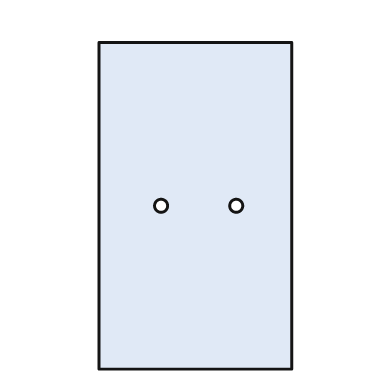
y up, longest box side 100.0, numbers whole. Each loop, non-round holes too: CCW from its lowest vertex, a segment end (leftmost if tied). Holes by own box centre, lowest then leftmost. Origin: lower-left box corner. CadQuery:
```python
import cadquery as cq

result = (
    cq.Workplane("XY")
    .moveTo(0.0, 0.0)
    .lineTo(59.0, 0.0)
    .lineTo(59.0, 100.0)
    .lineTo(0.0, 100.0)
    .close()
    .moveTo(19.0, 50.0)
    .circle(2.0)
    .moveTo(42.0, 50.0)
    .circle(2.0)
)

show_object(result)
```